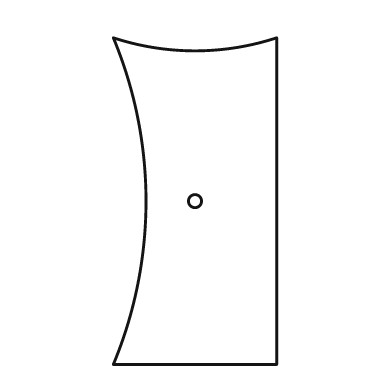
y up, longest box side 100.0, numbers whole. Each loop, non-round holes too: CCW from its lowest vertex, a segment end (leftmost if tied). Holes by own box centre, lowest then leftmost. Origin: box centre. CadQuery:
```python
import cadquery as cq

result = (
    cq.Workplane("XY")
    .moveTo(-25.0, -50.0)
    .lineTo(25.0, -50.0)
    .lineTo(25.0, 50.0)
    .threePointArc((0.0, 46.0), (-25.0, 50.0))
    .threePointArc((-15.0, 0.0), (-25.0, -50.0))
    .close()
    .moveTo(0.0, 0.0)
    .circle(2.0)
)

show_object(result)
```